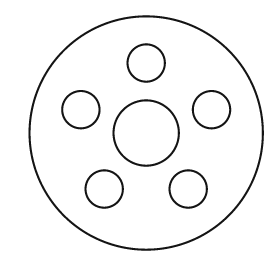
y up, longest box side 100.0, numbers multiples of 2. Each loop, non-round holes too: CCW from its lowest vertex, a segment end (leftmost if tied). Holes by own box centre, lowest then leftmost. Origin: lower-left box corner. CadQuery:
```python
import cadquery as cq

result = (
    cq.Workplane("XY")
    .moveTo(50.0, 50.0)
    .circle(50.0)
    .moveTo(32.0, 26.0)
    .circle(8.0)
    .moveTo(68.0, 26.0)
    .circle(8.0)
    .moveTo(50.0, 50.0)
    .circle(14.0)
    .moveTo(22.0, 60.0)
    .circle(8.0)
    .moveTo(78.0, 60.0)
    .circle(8.0)
    .moveTo(50.0, 80.0)
    .circle(8.0)
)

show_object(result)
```